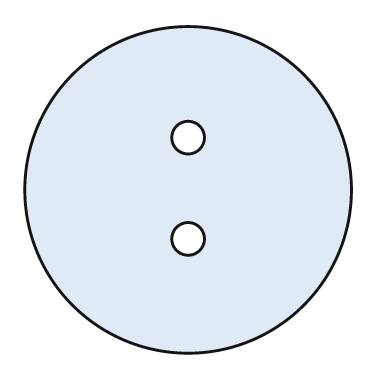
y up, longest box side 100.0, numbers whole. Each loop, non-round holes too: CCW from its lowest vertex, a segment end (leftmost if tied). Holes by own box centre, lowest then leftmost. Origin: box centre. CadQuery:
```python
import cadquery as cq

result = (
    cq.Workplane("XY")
    .moveTo(0.0, 0.0)
    .circle(50.0)
    .moveTo(0.0, -15.0)
    .circle(5.0)
    .moveTo(0.0, 16.0)
    .circle(5.0)
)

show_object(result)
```